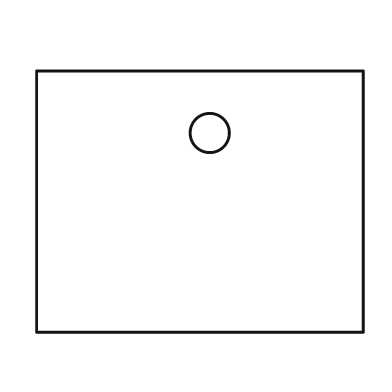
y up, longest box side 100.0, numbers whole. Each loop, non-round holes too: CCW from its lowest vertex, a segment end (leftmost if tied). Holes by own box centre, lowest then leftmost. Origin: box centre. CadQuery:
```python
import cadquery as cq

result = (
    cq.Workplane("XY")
    .moveTo(-50.0, -40.0)
    .lineTo(50.0, -40.0)
    .lineTo(50.0, 40.0)
    .lineTo(-50.0, 40.0)
    .close()
    .moveTo(3.0, 21.0)
    .circle(6.0)
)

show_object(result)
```